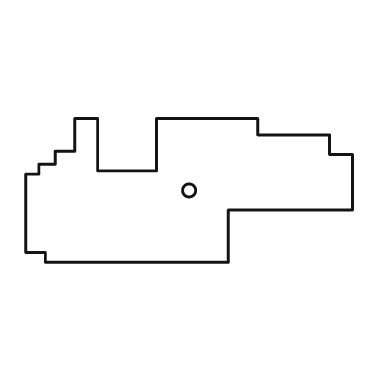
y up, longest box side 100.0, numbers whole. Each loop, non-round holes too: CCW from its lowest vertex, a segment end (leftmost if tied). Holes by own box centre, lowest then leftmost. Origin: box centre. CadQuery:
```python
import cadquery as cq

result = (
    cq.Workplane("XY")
    .moveTo(-44.0, -22.0)
    .lineTo(12.0, -22.0)
    .lineTo(12.0, -6.0)
    .lineTo(50.0, -6.0)
    .lineTo(50.0, 11.0)
    .lineTo(43.0, 11.0)
    .lineTo(43.0, 17.0)
    .lineTo(21.0, 17.0)
    .lineTo(21.0, 22.0)
    .lineTo(-10.0, 22.0)
    .lineTo(-10.0, 6.0)
    .lineTo(-28.0, 6.0)
    .lineTo(-28.0, 22.0)
    .lineTo(-35.0, 22.0)
    .lineTo(-35.0, 12.0)
    .lineTo(-41.0, 12.0)
    .lineTo(-41.0, 8.0)
    .lineTo(-46.0, 8.0)
    .lineTo(-46.0, 5.0)
    .lineTo(-50.0, 5.0)
    .lineTo(-50.0, -19.0)
    .lineTo(-44.0, -19.0)
    .close()
    .moveTo(0.0, 0.0)
    .circle(2.0)
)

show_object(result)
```